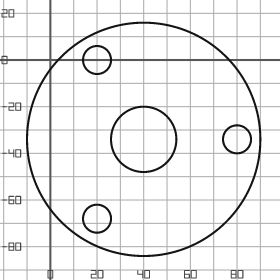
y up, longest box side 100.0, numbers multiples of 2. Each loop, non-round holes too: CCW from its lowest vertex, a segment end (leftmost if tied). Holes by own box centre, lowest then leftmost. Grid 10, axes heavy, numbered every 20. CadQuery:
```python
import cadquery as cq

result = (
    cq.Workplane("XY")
    .moveTo(40.0, -34.0)
    .circle(50.0)
    .moveTo(20.0, -68.0)
    .circle(6.0)
    .moveTo(40.0, -34.0)
    .circle(14.0)
    .moveTo(80.0, -34.0)
    .circle(6.0)
    .moveTo(20.0, 0.0)
    .circle(6.0)
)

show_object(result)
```